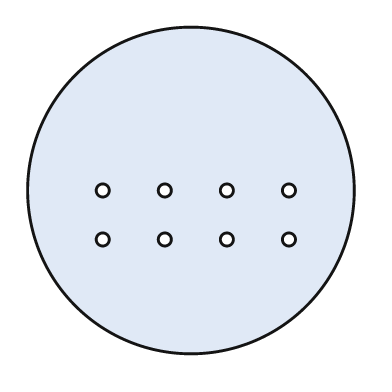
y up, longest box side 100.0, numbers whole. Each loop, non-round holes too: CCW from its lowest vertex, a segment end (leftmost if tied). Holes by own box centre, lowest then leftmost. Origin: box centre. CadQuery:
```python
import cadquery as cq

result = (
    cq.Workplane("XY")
    .moveTo(0.0, 0.0)
    .circle(50.0)
    .moveTo(-27.0, -15.0)
    .circle(2.0)
    .moveTo(-8.0, -15.0)
    .circle(2.0)
    .moveTo(11.0, -15.0)
    .circle(2.0)
    .moveTo(30.0, -15.0)
    .circle(2.0)
    .moveTo(-27.0, 0.0)
    .circle(2.0)
    .moveTo(-8.0, 0.0)
    .circle(2.0)
    .moveTo(11.0, 0.0)
    .circle(2.0)
    .moveTo(30.0, 0.0)
    .circle(2.0)
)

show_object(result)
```